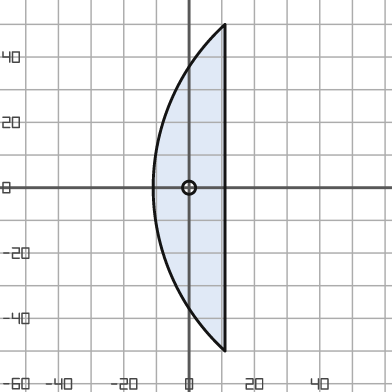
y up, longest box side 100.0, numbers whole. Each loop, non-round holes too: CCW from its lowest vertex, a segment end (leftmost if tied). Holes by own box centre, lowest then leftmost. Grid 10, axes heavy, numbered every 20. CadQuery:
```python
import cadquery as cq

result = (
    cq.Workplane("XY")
    .moveTo(11.0, -50.0)
    .lineTo(11.0, 50.0)
    .threePointArc((-11.0, 0.0), (11.0, -50.0))
    .close()
    .moveTo(0.0, 0.0)
    .circle(2.0)
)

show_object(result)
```